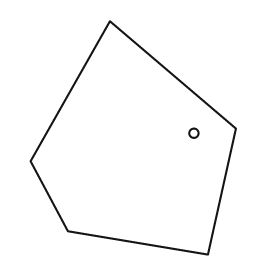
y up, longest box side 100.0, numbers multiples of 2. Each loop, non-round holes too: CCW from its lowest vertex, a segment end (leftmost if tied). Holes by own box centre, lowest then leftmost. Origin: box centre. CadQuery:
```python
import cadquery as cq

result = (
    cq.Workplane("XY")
    .moveTo(32.0, -50.0)
    .lineTo(44.0, 4.0)
    .lineTo(-10.0, 50.0)
    .lineTo(-44.0, -10.0)
    .lineTo(-28.0, -40.0)
    .close()
    .moveTo(26.0, 2.0)
    .circle(2.0)
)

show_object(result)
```